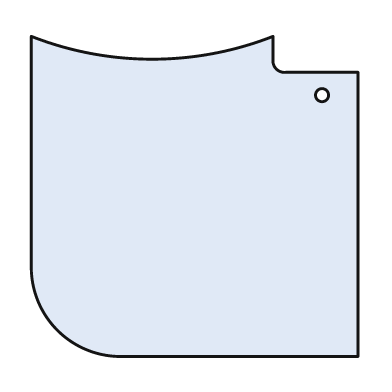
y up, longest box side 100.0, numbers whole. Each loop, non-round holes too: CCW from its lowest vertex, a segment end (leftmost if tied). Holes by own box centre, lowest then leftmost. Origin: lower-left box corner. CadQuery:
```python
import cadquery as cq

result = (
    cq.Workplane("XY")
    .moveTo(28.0, 0.0)
    .lineTo(100.0, 0.0)
    .lineTo(100.0, 87.0)
    .lineTo(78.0, 87.0)
    .threePointArc((75.0, 88.0), (74.0, 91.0))
    .lineTo(74.0, 98.0)
    .threePointArc((37.0, 91.0), (0.0, 98.0))
    .lineTo(0.0, 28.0)
    .threePointArc((8.0, 8.0), (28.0, 0.0))
    .close()
    .moveTo(89.0, 80.0)
    .circle(2.0)
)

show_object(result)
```